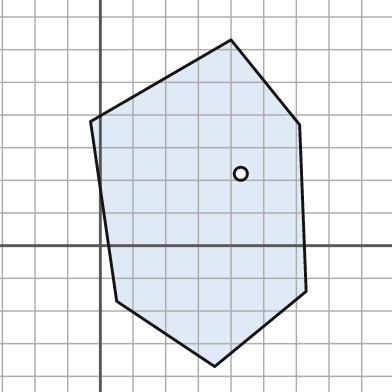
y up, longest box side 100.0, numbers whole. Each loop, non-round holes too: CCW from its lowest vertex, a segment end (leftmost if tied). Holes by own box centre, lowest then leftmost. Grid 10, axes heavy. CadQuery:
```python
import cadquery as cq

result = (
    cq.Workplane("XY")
    .moveTo(35.0, -37.0)
    .lineTo(63.0, -14.0)
    .lineTo(61.0, 37.0)
    .lineTo(40.0, 63.0)
    .lineTo(-3.0, 38.0)
    .lineTo(5.0, -17.0)
    .close()
    .moveTo(43.0, 22.0)
    .circle(2.0)
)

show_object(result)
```